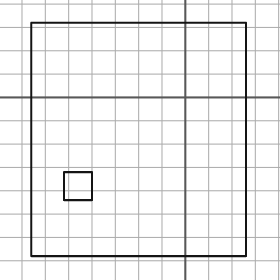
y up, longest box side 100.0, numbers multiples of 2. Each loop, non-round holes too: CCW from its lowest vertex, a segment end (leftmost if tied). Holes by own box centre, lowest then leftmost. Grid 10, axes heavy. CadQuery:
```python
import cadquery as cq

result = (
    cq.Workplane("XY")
    .moveTo(-66.0, -68.0)
    .lineTo(26.0, -68.0)
    .lineTo(26.0, 32.0)
    .lineTo(-66.0, 32.0)
    .close()
    .moveTo(-52.0, -44.0)
    .lineTo(-40.0, -44.0)
    .lineTo(-40.0, -32.0)
    .lineTo(-52.0, -32.0)
    .close()
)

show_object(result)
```